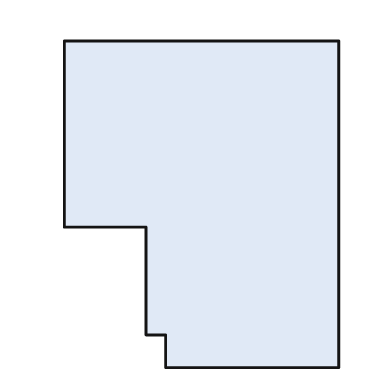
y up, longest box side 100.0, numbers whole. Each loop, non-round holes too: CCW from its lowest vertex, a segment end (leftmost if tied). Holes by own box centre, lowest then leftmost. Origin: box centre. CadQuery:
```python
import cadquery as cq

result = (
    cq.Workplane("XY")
    .moveTo(-11.0, -50.0)
    .lineTo(42.0, -50.0)
    .lineTo(42.0, 50.0)
    .lineTo(-42.0, 50.0)
    .lineTo(-42.0, -7.0)
    .lineTo(-17.0, -7.0)
    .lineTo(-17.0, -40.0)
    .lineTo(-11.0, -40.0)
    .close()
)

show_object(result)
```